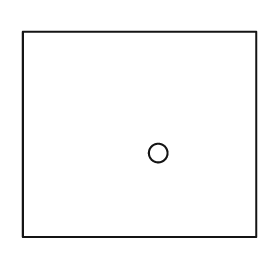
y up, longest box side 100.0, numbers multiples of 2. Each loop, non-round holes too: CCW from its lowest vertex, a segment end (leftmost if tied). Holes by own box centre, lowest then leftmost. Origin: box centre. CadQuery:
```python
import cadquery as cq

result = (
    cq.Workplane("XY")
    .moveTo(-50.0, -44.0)
    .lineTo(50.0, -44.0)
    .lineTo(50.0, 44.0)
    .lineTo(-50.0, 44.0)
    .close()
    .moveTo(8.0, -8.0)
    .circle(4.0)
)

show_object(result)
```